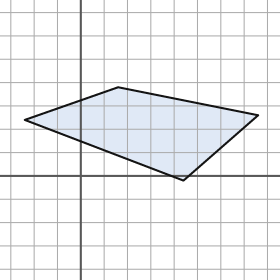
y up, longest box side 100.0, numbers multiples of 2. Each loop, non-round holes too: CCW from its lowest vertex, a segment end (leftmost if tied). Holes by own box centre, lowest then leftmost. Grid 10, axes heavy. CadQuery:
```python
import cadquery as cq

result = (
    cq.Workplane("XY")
    .moveTo(44.0, -2.0)
    .lineTo(76.0, 26.0)
    .lineTo(16.0, 38.0)
    .lineTo(-24.0, 24.0)
    .close()
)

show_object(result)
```